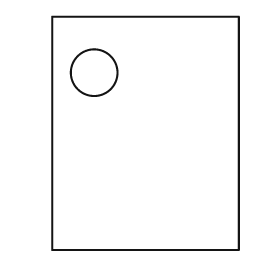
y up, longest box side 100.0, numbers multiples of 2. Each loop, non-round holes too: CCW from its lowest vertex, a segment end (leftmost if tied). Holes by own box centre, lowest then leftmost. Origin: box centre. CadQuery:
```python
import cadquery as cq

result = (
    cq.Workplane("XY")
    .moveTo(-40.0, -50.0)
    .lineTo(40.0, -50.0)
    .lineTo(40.0, 50.0)
    .lineTo(-40.0, 50.0)
    .close()
    .moveTo(-22.0, 26.0)
    .circle(10.0)
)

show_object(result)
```